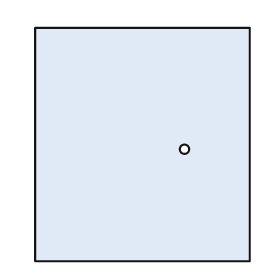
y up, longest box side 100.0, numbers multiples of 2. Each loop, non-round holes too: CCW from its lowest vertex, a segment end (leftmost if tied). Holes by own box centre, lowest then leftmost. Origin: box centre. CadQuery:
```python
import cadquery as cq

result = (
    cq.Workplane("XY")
    .moveTo(-46.0, -50.0)
    .lineTo(46.0, -50.0)
    .lineTo(46.0, 50.0)
    .lineTo(-46.0, 50.0)
    .close()
    .moveTo(18.0, -2.0)
    .circle(2.0)
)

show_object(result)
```